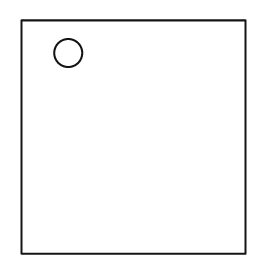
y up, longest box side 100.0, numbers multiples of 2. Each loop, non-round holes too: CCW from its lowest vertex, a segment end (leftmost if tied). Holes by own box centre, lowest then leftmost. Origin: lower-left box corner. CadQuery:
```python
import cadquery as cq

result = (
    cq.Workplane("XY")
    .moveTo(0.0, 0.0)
    .lineTo(96.0, 0.0)
    .lineTo(96.0, 100.0)
    .lineTo(0.0, 100.0)
    .close()
    .moveTo(20.0, 86.0)
    .circle(6.0)
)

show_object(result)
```